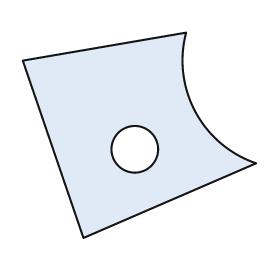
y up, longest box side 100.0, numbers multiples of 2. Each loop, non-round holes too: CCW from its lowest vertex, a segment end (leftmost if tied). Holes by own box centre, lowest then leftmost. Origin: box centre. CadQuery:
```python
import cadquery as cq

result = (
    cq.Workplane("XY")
    .moveTo(-24.0, -44.0)
    .lineTo(50.0, -12.0)
    .threePointArc((24.0, 10.0), (20.0, 44.0))
    .lineTo(-50.0, 32.0)
    .close()
    .moveTo(-2.0, -6.0)
    .circle(10.0)
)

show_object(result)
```